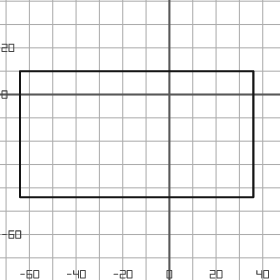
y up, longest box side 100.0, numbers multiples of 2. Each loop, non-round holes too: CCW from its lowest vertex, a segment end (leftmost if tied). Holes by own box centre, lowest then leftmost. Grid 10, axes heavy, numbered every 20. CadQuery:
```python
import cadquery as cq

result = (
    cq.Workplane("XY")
    .moveTo(-64.0, -44.0)
    .lineTo(36.0, -44.0)
    .lineTo(36.0, 10.0)
    .lineTo(-64.0, 10.0)
    .close()
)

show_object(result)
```